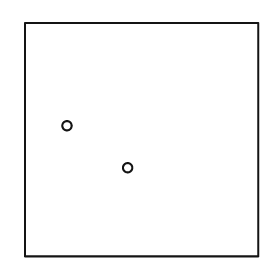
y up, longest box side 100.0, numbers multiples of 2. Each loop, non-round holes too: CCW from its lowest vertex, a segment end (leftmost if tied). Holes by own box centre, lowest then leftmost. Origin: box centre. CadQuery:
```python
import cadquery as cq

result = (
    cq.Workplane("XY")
    .moveTo(-50.0, -50.0)
    .lineTo(50.0, -50.0)
    .lineTo(50.0, 50.0)
    .lineTo(-50.0, 50.0)
    .close()
    .moveTo(-6.0, -12.0)
    .circle(2.0)
    .moveTo(-32.0, 6.0)
    .circle(2.0)
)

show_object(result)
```